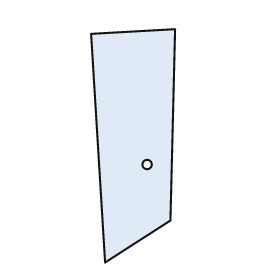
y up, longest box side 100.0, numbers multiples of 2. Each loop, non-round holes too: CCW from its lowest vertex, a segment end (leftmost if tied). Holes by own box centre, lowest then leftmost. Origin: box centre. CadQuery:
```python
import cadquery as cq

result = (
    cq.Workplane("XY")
    .moveTo(-12.0, -50.0)
    .lineTo(16.0, -32.0)
    .lineTo(18.0, 50.0)
    .lineTo(-18.0, 48.0)
    .close()
    .moveTo(6.0, -8.0)
    .circle(2.0)
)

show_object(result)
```